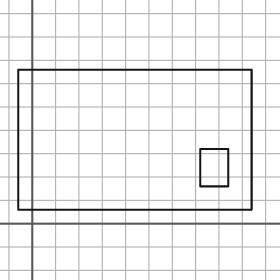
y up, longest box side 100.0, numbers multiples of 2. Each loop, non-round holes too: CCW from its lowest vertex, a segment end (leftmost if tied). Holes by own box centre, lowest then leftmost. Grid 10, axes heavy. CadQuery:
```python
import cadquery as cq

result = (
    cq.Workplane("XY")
    .moveTo(-6.0, 6.0)
    .lineTo(94.0, 6.0)
    .lineTo(94.0, 66.0)
    .lineTo(-6.0, 66.0)
    .close()
    .moveTo(72.0, 16.0)
    .lineTo(84.0, 16.0)
    .lineTo(84.0, 32.0)
    .lineTo(72.0, 32.0)
    .close()
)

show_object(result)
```